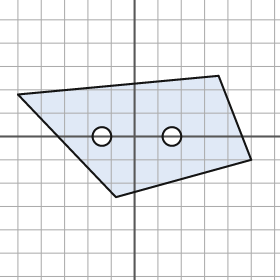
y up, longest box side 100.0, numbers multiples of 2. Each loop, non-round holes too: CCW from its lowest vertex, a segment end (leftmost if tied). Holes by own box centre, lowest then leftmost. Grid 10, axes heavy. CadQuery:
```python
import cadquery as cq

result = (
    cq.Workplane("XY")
    .moveTo(-8.0, -26.0)
    .lineTo(50.0, -10.0)
    .lineTo(36.0, 26.0)
    .lineTo(-50.0, 18.0)
    .close()
    .moveTo(-14.0, 0.0)
    .circle(4.0)
    .moveTo(16.0, 0.0)
    .circle(4.0)
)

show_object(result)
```